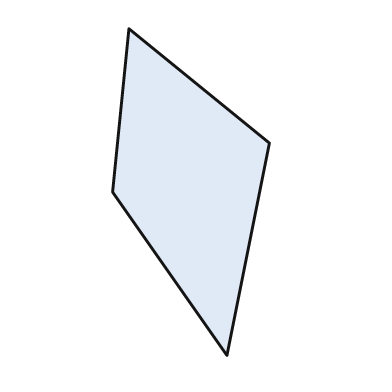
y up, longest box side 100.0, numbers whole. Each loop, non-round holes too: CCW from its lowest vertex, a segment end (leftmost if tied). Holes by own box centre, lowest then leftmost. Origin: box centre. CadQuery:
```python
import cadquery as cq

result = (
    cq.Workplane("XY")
    .moveTo(11.0, -50.0)
    .lineTo(24.0, 15.0)
    .lineTo(-19.0, 50.0)
    .lineTo(-24.0, 0.0)
    .close()
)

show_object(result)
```